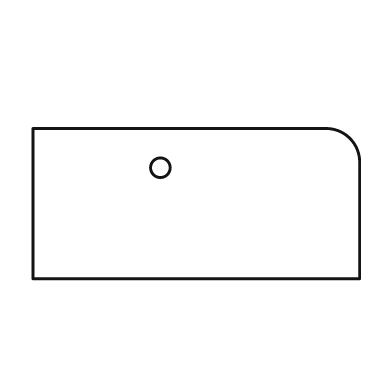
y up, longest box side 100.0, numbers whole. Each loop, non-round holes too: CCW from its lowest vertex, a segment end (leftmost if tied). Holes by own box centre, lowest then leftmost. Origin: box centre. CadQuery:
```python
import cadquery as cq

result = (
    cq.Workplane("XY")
    .moveTo(-50.0, -23.0)
    .lineTo(50.0, -23.0)
    .lineTo(50.0, 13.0)
    .threePointArc((47.0, 20.0), (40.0, 23.0))
    .lineTo(-50.0, 23.0)
    .close()
    .moveTo(-11.0, 11.0)
    .circle(3.0)
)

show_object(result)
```